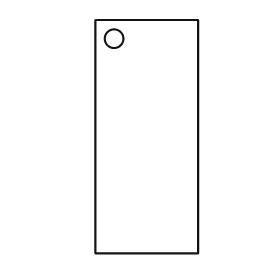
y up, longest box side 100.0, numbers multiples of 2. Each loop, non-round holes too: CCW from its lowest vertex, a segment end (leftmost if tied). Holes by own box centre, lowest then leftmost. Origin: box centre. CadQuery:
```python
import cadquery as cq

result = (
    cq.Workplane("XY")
    .moveTo(-22.0, -50.0)
    .lineTo(22.0, -50.0)
    .lineTo(22.0, 50.0)
    .lineTo(-22.0, 50.0)
    .close()
    .moveTo(-14.0, 42.0)
    .circle(4.0)
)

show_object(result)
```